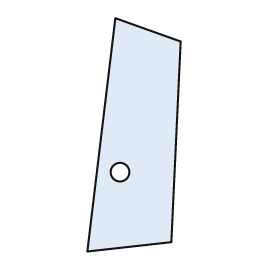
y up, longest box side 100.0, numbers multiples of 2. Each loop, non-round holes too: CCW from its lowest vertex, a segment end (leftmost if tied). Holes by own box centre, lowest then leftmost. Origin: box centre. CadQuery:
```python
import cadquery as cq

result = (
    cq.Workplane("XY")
    .moveTo(-20.0, -50.0)
    .lineTo(16.0, -46.0)
    .lineTo(20.0, 40.0)
    .lineTo(-8.0, 50.0)
    .close()
    .moveTo(-6.0, -16.0)
    .circle(4.0)
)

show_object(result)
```